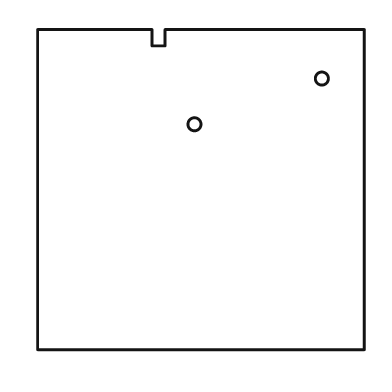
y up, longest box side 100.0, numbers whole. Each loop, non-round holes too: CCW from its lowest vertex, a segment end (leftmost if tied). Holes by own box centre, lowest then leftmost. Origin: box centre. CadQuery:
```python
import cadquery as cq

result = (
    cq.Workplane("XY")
    .moveTo(-50.0, -49.0)
    .lineTo(50.0, -49.0)
    .lineTo(50.0, 49.0)
    .lineTo(-11.0, 49.0)
    .lineTo(-11.0, 44.0)
    .lineTo(-15.0, 44.0)
    .lineTo(-15.0, 49.0)
    .lineTo(-50.0, 49.0)
    .close()
    .moveTo(-2.0, 20.0)
    .circle(2.0)
    .moveTo(37.0, 34.0)
    .circle(2.0)
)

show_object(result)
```